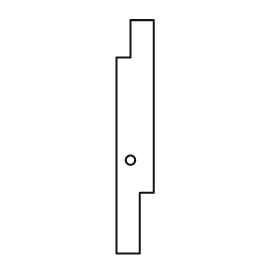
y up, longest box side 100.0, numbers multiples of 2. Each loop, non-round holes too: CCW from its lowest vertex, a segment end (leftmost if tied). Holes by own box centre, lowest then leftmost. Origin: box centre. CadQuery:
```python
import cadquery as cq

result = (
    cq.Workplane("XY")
    .moveTo(-8.0, -50.0)
    .lineTo(2.0, -50.0)
    .lineTo(2.0, -24.0)
    .lineTo(8.0, -24.0)
    .lineTo(8.0, 50.0)
    .lineTo(-2.0, 50.0)
    .lineTo(-2.0, 34.0)
    .lineTo(-8.0, 34.0)
    .close()
    .moveTo(-2.0, -10.0)
    .circle(2.0)
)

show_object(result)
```